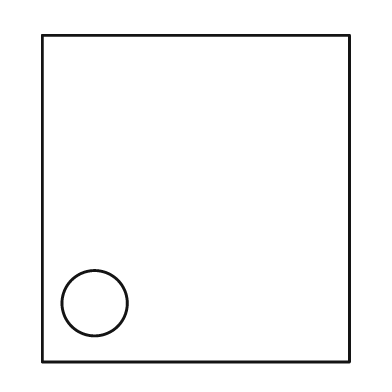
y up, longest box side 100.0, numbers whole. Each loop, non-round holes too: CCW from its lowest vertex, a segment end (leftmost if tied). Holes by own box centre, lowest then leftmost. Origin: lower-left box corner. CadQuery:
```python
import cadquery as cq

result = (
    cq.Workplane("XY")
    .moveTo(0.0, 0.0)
    .lineTo(94.0, 0.0)
    .lineTo(94.0, 100.0)
    .lineTo(0.0, 100.0)
    .close()
    .moveTo(16.0, 18.0)
    .circle(10.0)
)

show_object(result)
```